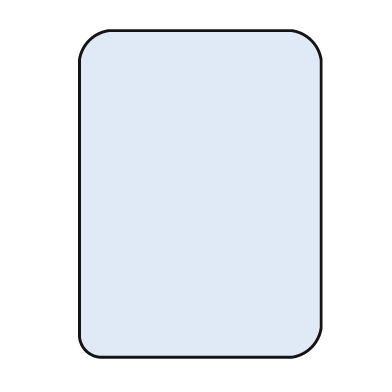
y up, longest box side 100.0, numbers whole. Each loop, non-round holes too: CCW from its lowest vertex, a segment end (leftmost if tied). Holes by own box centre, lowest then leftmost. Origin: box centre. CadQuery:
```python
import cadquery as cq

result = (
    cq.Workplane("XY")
    .moveTo(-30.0, -50.0)
    .lineTo(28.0, -50.0)
    .threePointArc((34.0, -47.0), (37.0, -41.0))
    .lineTo(37.0, 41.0)
    .threePointArc((34.0, 47.0), (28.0, 50.0))
    .lineTo(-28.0, 50.0)
    .threePointArc((-34.0, 47.0), (-37.0, 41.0))
    .lineTo(-37.0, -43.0)
    .threePointArc((-35.0, -48.0), (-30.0, -50.0))
    .close()
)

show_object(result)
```